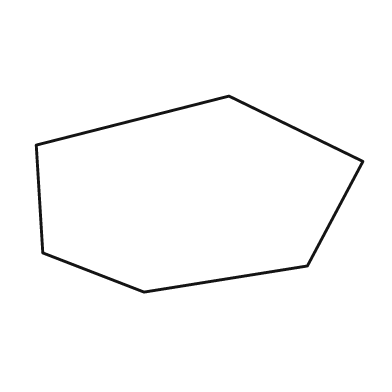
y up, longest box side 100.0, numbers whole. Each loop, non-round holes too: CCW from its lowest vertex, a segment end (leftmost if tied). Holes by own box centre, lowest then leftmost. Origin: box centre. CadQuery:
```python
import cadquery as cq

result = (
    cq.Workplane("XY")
    .moveTo(-17.0, -30.0)
    .lineTo(33.0, -22.0)
    .lineTo(50.0, 10.0)
    .lineTo(9.0, 30.0)
    .lineTo(-50.0, 15.0)
    .lineTo(-48.0, -18.0)
    .close()
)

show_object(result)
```